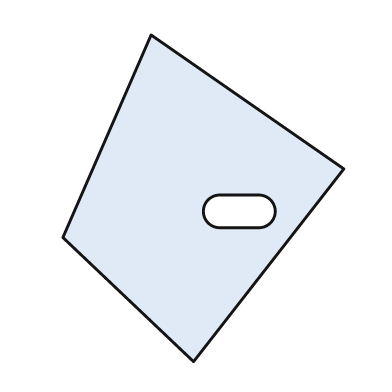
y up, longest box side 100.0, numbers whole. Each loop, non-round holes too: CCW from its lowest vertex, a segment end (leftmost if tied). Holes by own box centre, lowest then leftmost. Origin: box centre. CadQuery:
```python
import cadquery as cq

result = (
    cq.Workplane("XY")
    .moveTo(-3.0, -50.0)
    .lineTo(43.0, 9.0)
    .lineTo(-16.0, 50.0)
    .lineTo(-43.0, -12.0)
    .close()
    .moveTo(5.0, -9.0)
    .lineTo(17.0, -9.0)
    .threePointArc((22.0, -4.0), (17.0, 1.0))
    .lineTo(5.0, 1.0)
    .threePointArc((0.0, -4.0), (5.0, -9.0))
    .close()
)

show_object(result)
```